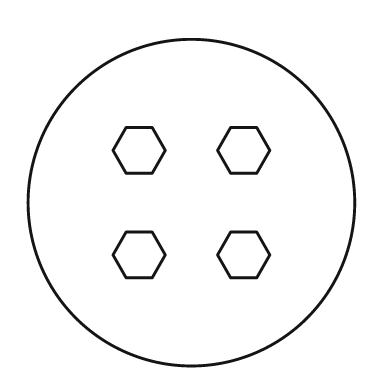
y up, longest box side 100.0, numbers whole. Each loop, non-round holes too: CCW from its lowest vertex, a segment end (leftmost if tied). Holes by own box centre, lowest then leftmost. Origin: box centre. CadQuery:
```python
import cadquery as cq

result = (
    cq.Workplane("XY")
    .moveTo(0.0, 0.0)
    .circle(50.0)
    .moveTo(-20.0, -23.0)
    .lineTo(-12.0, -23.0)
    .lineTo(-8.0, -16.0)
    .lineTo(-12.0, -9.0)
    .lineTo(-20.0, -9.0)
    .lineTo(-24.0, -16.0)
    .close()
    .moveTo(12.0, -23.0)
    .lineTo(20.0, -23.0)
    .lineTo(24.0, -16.0)
    .lineTo(20.0, -9.0)
    .lineTo(12.0, -9.0)
    .lineTo(8.0, -16.0)
    .close()
    .moveTo(-20.0, 9.0)
    .lineTo(-12.0, 9.0)
    .lineTo(-8.0, 16.0)
    .lineTo(-12.0, 23.0)
    .lineTo(-20.0, 23.0)
    .lineTo(-24.0, 16.0)
    .close()
    .moveTo(12.0, 9.0)
    .lineTo(20.0, 9.0)
    .lineTo(24.0, 16.0)
    .lineTo(20.0, 23.0)
    .lineTo(12.0, 23.0)
    .lineTo(8.0, 16.0)
    .close()
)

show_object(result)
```